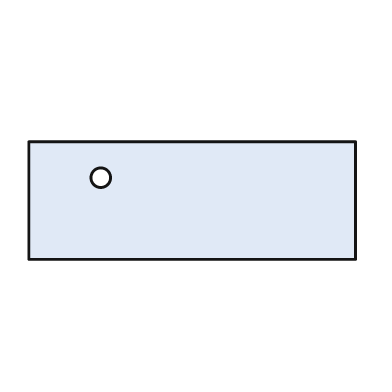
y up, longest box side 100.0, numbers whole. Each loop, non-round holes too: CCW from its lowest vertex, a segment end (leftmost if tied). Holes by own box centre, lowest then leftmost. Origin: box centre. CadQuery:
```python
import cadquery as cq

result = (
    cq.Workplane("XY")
    .moveTo(-50.0, -18.0)
    .lineTo(50.0, -18.0)
    .lineTo(50.0, 18.0)
    .lineTo(-50.0, 18.0)
    .close()
    .moveTo(-28.0, 7.0)
    .circle(3.0)
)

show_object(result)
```